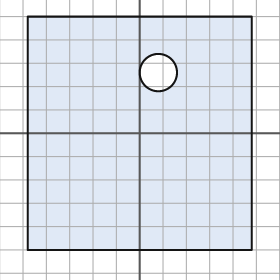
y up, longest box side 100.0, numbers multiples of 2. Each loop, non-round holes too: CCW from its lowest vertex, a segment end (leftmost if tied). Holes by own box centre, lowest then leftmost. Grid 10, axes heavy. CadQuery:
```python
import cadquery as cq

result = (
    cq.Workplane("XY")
    .moveTo(-48.0, -50.0)
    .lineTo(48.0, -50.0)
    .lineTo(48.0, 50.0)
    .lineTo(-48.0, 50.0)
    .close()
    .moveTo(8.0, 26.0)
    .circle(8.0)
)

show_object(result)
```